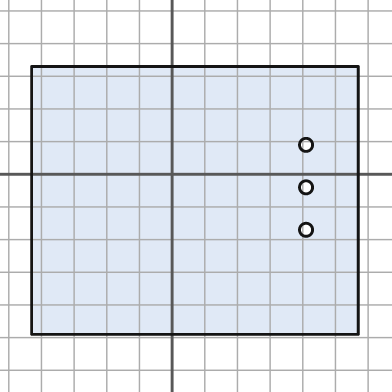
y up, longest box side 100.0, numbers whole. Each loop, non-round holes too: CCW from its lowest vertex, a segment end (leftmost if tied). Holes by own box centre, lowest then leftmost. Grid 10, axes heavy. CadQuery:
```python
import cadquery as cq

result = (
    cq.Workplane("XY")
    .moveTo(-43.0, -49.0)
    .lineTo(57.0, -49.0)
    .lineTo(57.0, 33.0)
    .lineTo(-43.0, 33.0)
    .close()
    .moveTo(41.0, -17.0)
    .circle(2.0)
    .moveTo(41.0, -4.0)
    .circle(2.0)
    .moveTo(41.0, 9.0)
    .circle(2.0)
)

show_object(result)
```